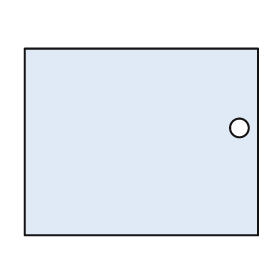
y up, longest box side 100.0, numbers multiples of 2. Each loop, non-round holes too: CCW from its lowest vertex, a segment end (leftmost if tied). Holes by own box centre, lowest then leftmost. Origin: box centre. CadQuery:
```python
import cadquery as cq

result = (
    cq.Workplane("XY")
    .moveTo(-50.0, -40.0)
    .lineTo(50.0, -40.0)
    .lineTo(50.0, 40.0)
    .lineTo(-50.0, 40.0)
    .close()
    .moveTo(42.0, 6.0)
    .circle(4.0)
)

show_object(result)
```